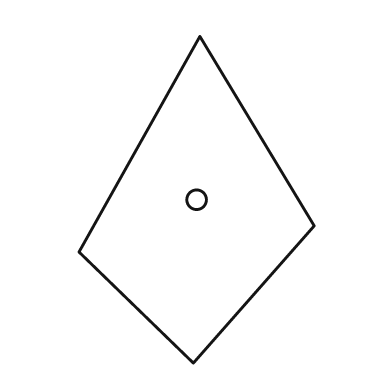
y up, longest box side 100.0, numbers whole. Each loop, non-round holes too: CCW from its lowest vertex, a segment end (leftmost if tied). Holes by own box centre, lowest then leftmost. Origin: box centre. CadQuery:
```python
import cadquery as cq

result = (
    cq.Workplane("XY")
    .moveTo(-1.0, -50.0)
    .lineTo(36.0, -8.0)
    .lineTo(1.0, 50.0)
    .lineTo(-36.0, -16.0)
    .close()
    .moveTo(0.0, 0.0)
    .circle(3.0)
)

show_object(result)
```